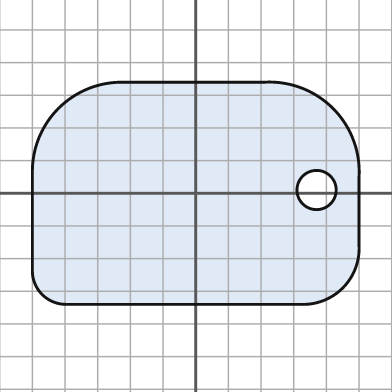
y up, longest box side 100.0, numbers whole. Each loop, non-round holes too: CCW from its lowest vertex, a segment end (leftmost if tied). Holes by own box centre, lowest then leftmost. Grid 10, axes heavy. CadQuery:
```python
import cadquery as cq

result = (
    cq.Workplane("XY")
    .moveTo(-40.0, -34.0)
    .lineTo(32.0, -34.0)
    .threePointArc((45.0, -29.0), (50.0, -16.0))
    .lineTo(50.0, 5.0)
    .threePointArc((42.0, 26.0), (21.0, 34.0))
    .lineTo(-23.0, 34.0)
    .threePointArc((-42.0, 26.0), (-50.0, 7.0))
    .lineTo(-50.0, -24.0)
    .threePointArc((-47.0, -31.0), (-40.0, -34.0))
    .close()
    .moveTo(37.0, 1.0)
    .circle(6.0)
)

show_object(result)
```